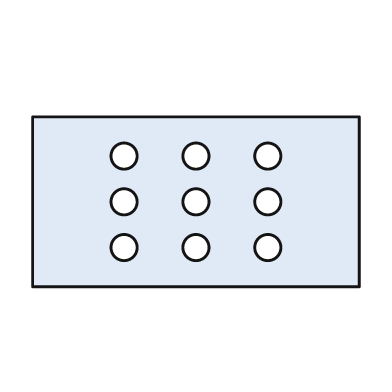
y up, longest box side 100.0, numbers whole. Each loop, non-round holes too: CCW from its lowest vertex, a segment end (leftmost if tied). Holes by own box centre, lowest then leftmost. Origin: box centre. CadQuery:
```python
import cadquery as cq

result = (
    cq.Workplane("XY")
    .moveTo(-50.0, -26.0)
    .lineTo(50.0, -26.0)
    .lineTo(50.0, 26.0)
    .lineTo(-50.0, 26.0)
    .close()
    .moveTo(-22.0, -14.0)
    .circle(4.0)
    .moveTo(0.0, -14.0)
    .circle(4.0)
    .moveTo(22.0, -14.0)
    .circle(4.0)
    .moveTo(-22.0, 0.0)
    .circle(4.0)
    .moveTo(0.0, 0.0)
    .circle(4.0)
    .moveTo(22.0, 0.0)
    .circle(4.0)
    .moveTo(-22.0, 14.0)
    .circle(4.0)
    .moveTo(0.0, 14.0)
    .circle(4.0)
    .moveTo(22.0, 14.0)
    .circle(4.0)
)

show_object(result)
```